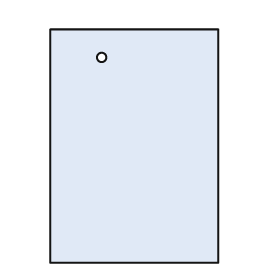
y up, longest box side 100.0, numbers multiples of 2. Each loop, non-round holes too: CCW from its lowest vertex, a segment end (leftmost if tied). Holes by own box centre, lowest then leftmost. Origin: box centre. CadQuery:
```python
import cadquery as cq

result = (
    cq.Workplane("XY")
    .moveTo(-36.0, -50.0)
    .lineTo(36.0, -50.0)
    .lineTo(36.0, 50.0)
    .lineTo(-36.0, 50.0)
    .close()
    .moveTo(-14.0, 38.0)
    .circle(2.0)
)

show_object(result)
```